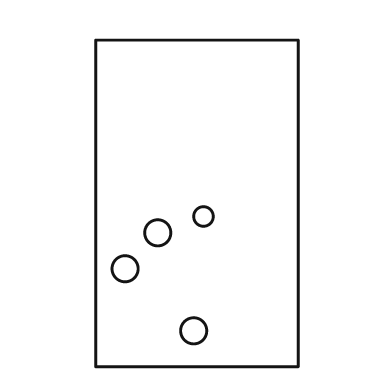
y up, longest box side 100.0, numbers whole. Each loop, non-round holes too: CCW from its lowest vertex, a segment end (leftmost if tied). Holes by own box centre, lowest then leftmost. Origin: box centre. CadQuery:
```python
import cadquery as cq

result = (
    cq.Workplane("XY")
    .moveTo(-31.0, -50.0)
    .lineTo(31.0, -50.0)
    .lineTo(31.0, 50.0)
    .lineTo(-31.0, 50.0)
    .close()
    .moveTo(-1.0, -39.0)
    .circle(4.0)
    .moveTo(-22.0, -20.0)
    .circle(4.0)
    .moveTo(-12.0, -9.0)
    .circle(4.0)
    .moveTo(2.0, -4.0)
    .circle(3.0)
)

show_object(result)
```